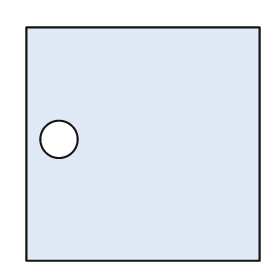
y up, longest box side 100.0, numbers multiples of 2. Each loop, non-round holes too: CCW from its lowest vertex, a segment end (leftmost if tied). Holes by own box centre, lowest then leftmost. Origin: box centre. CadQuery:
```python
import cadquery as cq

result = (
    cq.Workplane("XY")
    .moveTo(-50.0, -50.0)
    .lineTo(50.0, -50.0)
    .lineTo(50.0, 50.0)
    .lineTo(-50.0, 50.0)
    .close()
    .moveTo(-36.0, 2.0)
    .circle(8.0)
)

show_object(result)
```